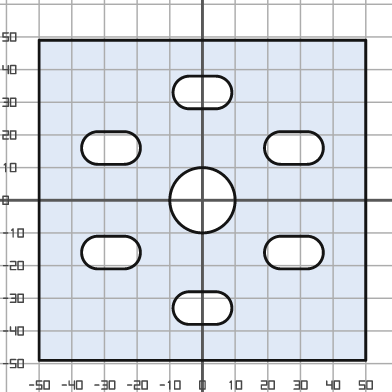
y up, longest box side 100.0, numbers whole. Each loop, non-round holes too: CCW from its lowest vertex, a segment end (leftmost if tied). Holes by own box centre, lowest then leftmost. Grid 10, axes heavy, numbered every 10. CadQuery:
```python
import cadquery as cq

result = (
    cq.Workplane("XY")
    .moveTo(-50.0, -49.0)
    .lineTo(50.0, -49.0)
    .lineTo(50.0, 49.0)
    .lineTo(-50.0, 49.0)
    .close()
    .moveTo(-4.0, -38.0)
    .lineTo(4.0, -38.0)
    .threePointArc((9.0, -33.0), (4.0, -28.0))
    .lineTo(-4.0, -28.0)
    .threePointArc((-9.0, -33.0), (-4.0, -38.0))
    .close()
    .moveTo(-32.0, -21.0)
    .lineTo(-24.0, -21.0)
    .threePointArc((-19.0, -16.0), (-24.0, -11.0))
    .lineTo(-32.0, -11.0)
    .threePointArc((-37.0, -16.0), (-32.0, -21.0))
    .close()
    .moveTo(24.0, -21.0)
    .lineTo(32.0, -21.0)
    .threePointArc((37.0, -16.0), (32.0, -11.0))
    .lineTo(24.0, -11.0)
    .threePointArc((19.0, -16.0), (24.0, -21.0))
    .close()
    .moveTo(0.0, 0.0)
    .circle(10.0)
    .moveTo(-32.0, 11.0)
    .lineTo(-24.0, 11.0)
    .threePointArc((-19.0, 16.0), (-24.0, 21.0))
    .lineTo(-32.0, 21.0)
    .threePointArc((-37.0, 16.0), (-32.0, 11.0))
    .close()
    .moveTo(24.0, 11.0)
    .lineTo(32.0, 11.0)
    .threePointArc((37.0, 16.0), (32.0, 21.0))
    .lineTo(24.0, 21.0)
    .threePointArc((19.0, 16.0), (24.0, 11.0))
    .close()
    .moveTo(-4.0, 28.0)
    .lineTo(4.0, 28.0)
    .threePointArc((9.0, 33.0), (4.0, 38.0))
    .lineTo(-4.0, 38.0)
    .threePointArc((-9.0, 33.0), (-4.0, 28.0))
    .close()
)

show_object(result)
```